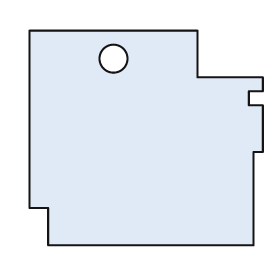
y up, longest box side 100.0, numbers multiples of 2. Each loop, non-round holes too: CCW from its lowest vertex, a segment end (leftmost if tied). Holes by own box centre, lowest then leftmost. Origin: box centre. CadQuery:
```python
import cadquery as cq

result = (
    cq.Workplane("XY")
    .moveTo(-42.0, -46.0)
    .lineTo(46.0, -46.0)
    .lineTo(46.0, -6.0)
    .lineTo(50.0, -6.0)
    .lineTo(50.0, 14.0)
    .lineTo(44.0, 14.0)
    .lineTo(44.0, 20.0)
    .lineTo(50.0, 20.0)
    .lineTo(50.0, 26.0)
    .lineTo(22.0, 26.0)
    .lineTo(22.0, 46.0)
    .lineTo(-50.0, 46.0)
    .lineTo(-50.0, -30.0)
    .lineTo(-42.0, -30.0)
    .close()
    .moveTo(-14.0, 34.0)
    .circle(6.0)
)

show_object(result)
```